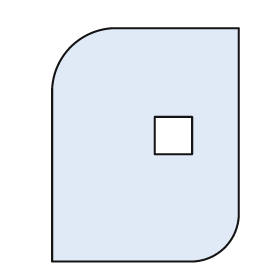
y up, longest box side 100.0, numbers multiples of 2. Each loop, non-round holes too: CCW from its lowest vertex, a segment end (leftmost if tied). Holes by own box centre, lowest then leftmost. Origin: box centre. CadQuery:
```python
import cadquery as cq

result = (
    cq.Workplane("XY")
    .moveTo(-40.0, -50.0)
    .lineTo(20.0, -50.0)
    .threePointArc((34.0, -44.0), (40.0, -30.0))
    .lineTo(40.0, 50.0)
    .lineTo(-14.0, 50.0)
    .threePointArc((-32.0, 42.0), (-40.0, 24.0))
    .close()
    .moveTo(4.0, -4.0)
    .lineTo(20.0, -4.0)
    .lineTo(20.0, 12.0)
    .lineTo(4.0, 12.0)
    .close()
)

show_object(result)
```